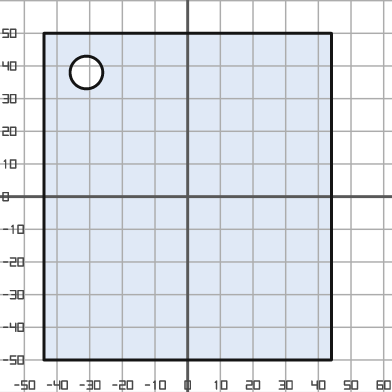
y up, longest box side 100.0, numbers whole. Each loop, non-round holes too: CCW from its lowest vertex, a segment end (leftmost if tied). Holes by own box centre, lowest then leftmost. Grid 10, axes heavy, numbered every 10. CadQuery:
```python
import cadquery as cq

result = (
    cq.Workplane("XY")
    .moveTo(-44.0, -50.0)
    .lineTo(44.0, -50.0)
    .lineTo(44.0, 50.0)
    .lineTo(-44.0, 50.0)
    .close()
    .moveTo(-31.0, 38.0)
    .circle(5.0)
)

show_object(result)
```